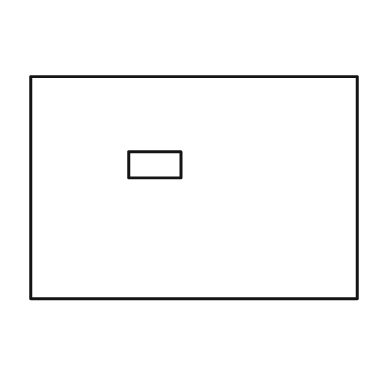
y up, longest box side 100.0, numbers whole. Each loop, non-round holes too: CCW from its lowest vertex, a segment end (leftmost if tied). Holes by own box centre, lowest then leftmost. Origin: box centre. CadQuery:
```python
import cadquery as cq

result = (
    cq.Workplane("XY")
    .moveTo(-50.0, -34.0)
    .lineTo(50.0, -34.0)
    .lineTo(50.0, 34.0)
    .lineTo(-50.0, 34.0)
    .close()
    .moveTo(-20.0, 3.0)
    .lineTo(-4.0, 3.0)
    .lineTo(-4.0, 11.0)
    .lineTo(-20.0, 11.0)
    .close()
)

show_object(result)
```